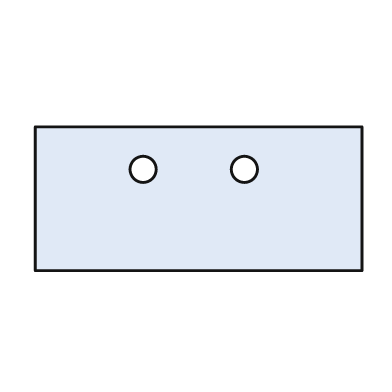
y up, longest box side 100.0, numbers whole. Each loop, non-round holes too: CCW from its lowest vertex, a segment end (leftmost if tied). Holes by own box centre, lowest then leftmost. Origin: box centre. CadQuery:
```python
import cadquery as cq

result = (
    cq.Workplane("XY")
    .moveTo(-50.0, -22.0)
    .lineTo(50.0, -22.0)
    .lineTo(50.0, 22.0)
    .lineTo(-50.0, 22.0)
    .close()
    .moveTo(-17.0, 9.0)
    .circle(4.0)
    .moveTo(14.0, 9.0)
    .circle(4.0)
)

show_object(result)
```